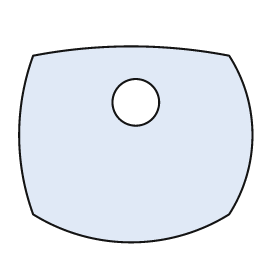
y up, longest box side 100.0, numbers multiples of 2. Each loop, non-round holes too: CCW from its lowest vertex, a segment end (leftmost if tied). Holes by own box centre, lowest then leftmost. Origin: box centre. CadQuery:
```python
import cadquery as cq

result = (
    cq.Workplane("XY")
    .moveTo(-44.0, -30.0)
    .threePointArc((-2.0, -42.0), (40.0, -30.0))
    .threePointArc((50.0, 4.0), (40.0, 38.0))
    .threePointArc((-2.0, 42.0), (-44.0, 38.0))
    .threePointArc((-50.0, 4.0), (-44.0, -30.0))
    .close()
    .moveTo(0.0, 18.0)
    .circle(10.0)
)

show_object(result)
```